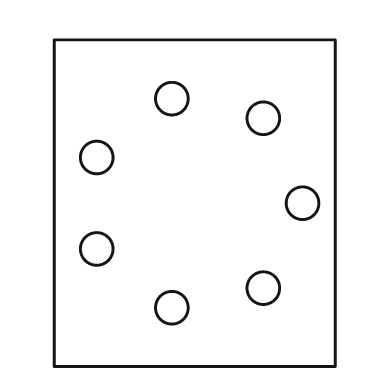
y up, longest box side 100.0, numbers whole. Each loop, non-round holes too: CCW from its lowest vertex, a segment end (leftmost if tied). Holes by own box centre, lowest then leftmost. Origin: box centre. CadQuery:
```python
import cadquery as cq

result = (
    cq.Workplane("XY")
    .moveTo(-43.0, -50.0)
    .lineTo(43.0, -50.0)
    .lineTo(43.0, 50.0)
    .lineTo(-43.0, 50.0)
    .close()
    .moveTo(-7.0, -32.0)
    .circle(5.0)
    .moveTo(21.0, -26.0)
    .circle(5.0)
    .moveTo(-30.0, -14.0)
    .circle(5.0)
    .moveTo(33.0, 0.0)
    .circle(5.0)
    .moveTo(-30.0, 14.0)
    .circle(5.0)
    .moveTo(21.0, 26.0)
    .circle(5.0)
    .moveTo(-7.0, 32.0)
    .circle(5.0)
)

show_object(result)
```